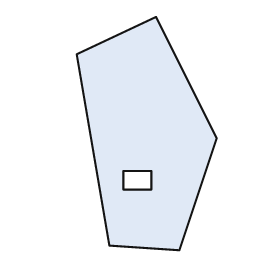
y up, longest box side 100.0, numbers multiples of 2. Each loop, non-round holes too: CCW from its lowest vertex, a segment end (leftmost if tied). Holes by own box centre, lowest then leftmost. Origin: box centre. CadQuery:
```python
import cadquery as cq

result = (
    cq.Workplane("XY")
    .moveTo(14.0, -50.0)
    .lineTo(30.0, -2.0)
    .lineTo(4.0, 50.0)
    .lineTo(-30.0, 34.0)
    .lineTo(-16.0, -48.0)
    .close()
    .moveTo(-10.0, -24.0)
    .lineTo(2.0, -24.0)
    .lineTo(2.0, -16.0)
    .lineTo(-10.0, -16.0)
    .close()
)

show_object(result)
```